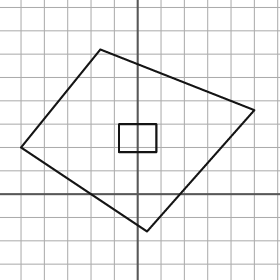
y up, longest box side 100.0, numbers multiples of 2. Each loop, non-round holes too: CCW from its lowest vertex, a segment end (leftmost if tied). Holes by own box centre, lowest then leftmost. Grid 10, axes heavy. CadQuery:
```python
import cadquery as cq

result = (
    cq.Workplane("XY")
    .moveTo(4.0, -16.0)
    .lineTo(50.0, 36.0)
    .lineTo(-16.0, 62.0)
    .lineTo(-50.0, 20.0)
    .close()
    .moveTo(-8.0, 18.0)
    .lineTo(8.0, 18.0)
    .lineTo(8.0, 30.0)
    .lineTo(-8.0, 30.0)
    .close()
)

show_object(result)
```